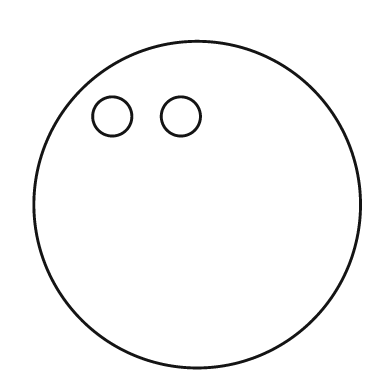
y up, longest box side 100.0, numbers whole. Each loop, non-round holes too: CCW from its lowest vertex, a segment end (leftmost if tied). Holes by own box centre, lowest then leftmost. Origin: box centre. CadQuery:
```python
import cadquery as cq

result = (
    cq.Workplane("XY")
    .moveTo(0.0, 0.0)
    .circle(50.0)
    .moveTo(-26.0, 27.0)
    .circle(6.0)
    .moveTo(-5.0, 27.0)
    .circle(6.0)
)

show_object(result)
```